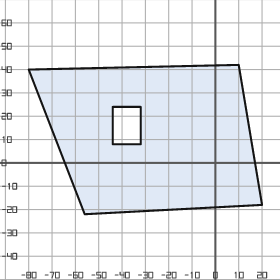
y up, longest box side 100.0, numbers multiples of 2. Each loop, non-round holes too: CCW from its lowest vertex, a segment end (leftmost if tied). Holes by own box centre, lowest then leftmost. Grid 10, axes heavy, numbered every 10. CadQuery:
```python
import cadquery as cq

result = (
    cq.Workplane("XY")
    .moveTo(-56.0, -22.0)
    .lineTo(20.0, -18.0)
    .lineTo(10.0, 42.0)
    .lineTo(-80.0, 40.0)
    .close()
    .moveTo(-44.0, 8.0)
    .lineTo(-32.0, 8.0)
    .lineTo(-32.0, 24.0)
    .lineTo(-44.0, 24.0)
    .close()
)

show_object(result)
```